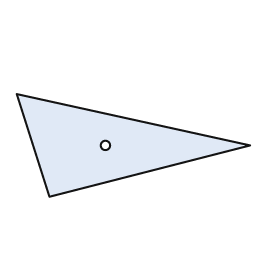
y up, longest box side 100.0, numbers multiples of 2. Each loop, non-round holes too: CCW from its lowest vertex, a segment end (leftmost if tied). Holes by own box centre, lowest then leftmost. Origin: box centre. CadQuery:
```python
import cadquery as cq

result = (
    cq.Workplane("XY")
    .moveTo(-36.0, -22.0)
    .lineTo(50.0, 0.0)
    .lineTo(-50.0, 22.0)
    .close()
    .moveTo(-12.0, 0.0)
    .circle(2.0)
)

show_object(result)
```